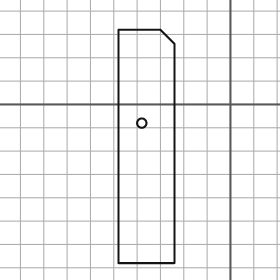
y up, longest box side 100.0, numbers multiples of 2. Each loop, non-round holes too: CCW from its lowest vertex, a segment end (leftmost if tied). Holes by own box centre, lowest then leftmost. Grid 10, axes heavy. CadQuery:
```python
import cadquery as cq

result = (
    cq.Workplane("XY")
    .moveTo(-48.0, -68.0)
    .lineTo(-24.0, -68.0)
    .lineTo(-24.0, 26.0)
    .lineTo(-30.0, 32.0)
    .lineTo(-48.0, 32.0)
    .close()
    .moveTo(-38.0, -8.0)
    .circle(2.0)
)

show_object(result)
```